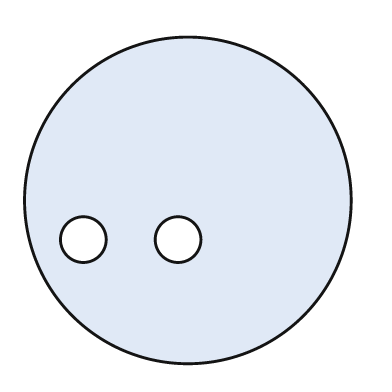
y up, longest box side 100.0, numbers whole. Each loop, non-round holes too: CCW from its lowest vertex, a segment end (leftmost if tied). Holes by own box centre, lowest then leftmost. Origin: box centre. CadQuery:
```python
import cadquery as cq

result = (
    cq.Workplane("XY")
    .moveTo(0.0, 0.0)
    .circle(50.0)
    .moveTo(-32.0, -12.0)
    .circle(7.0)
    .moveTo(-3.0, -12.0)
    .circle(7.0)
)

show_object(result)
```